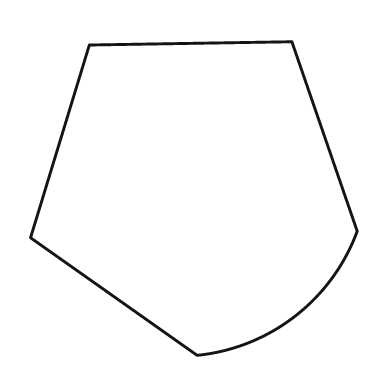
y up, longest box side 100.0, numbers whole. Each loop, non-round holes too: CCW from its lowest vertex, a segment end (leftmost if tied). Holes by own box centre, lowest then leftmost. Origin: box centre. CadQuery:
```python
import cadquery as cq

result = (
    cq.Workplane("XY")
    .moveTo(1.0, -48.0)
    .threePointArc((31.0, -36.0), (50.0, -10.0))
    .lineTo(30.0, 48.0)
    .lineTo(-32.0, 47.0)
    .lineTo(-50.0, -12.0)
    .close()
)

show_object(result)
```